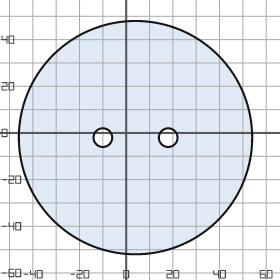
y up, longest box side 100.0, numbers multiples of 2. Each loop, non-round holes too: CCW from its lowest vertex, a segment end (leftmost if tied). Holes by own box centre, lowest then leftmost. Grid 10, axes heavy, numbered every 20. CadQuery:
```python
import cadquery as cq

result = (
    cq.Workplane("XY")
    .moveTo(4.0, -2.0)
    .circle(50.0)
    .moveTo(-10.0, -2.0)
    .circle(4.0)
    .moveTo(18.0, -2.0)
    .circle(4.0)
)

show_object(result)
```